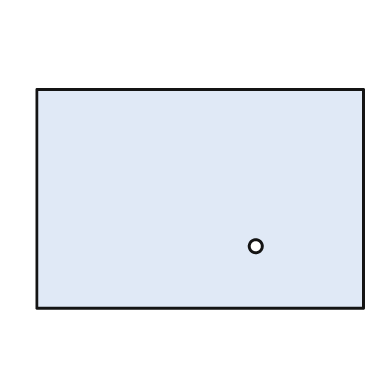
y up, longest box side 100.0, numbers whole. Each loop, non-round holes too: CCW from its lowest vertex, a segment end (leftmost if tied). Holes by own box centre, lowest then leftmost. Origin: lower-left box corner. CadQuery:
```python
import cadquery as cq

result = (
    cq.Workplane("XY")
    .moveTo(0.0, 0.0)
    .lineTo(100.0, 0.0)
    .lineTo(100.0, 67.0)
    .lineTo(0.0, 67.0)
    .close()
    .moveTo(67.0, 19.0)
    .circle(2.0)
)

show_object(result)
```